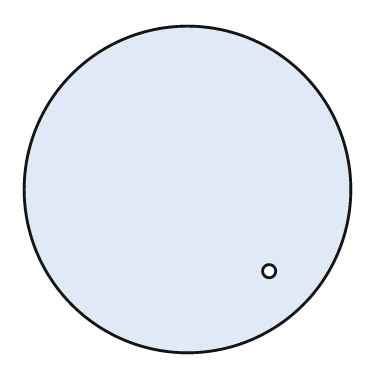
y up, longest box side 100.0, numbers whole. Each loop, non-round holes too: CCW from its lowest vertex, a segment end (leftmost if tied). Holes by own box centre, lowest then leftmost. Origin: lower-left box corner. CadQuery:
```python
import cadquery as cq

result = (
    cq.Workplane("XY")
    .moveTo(50.0, 50.0)
    .circle(50.0)
    .moveTo(75.0, 25.0)
    .circle(2.0)
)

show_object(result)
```